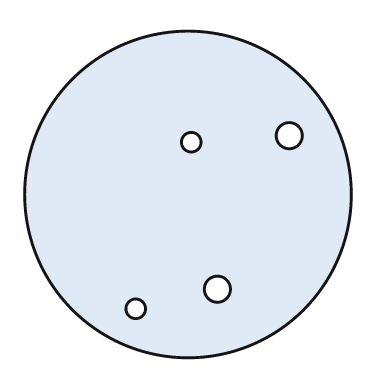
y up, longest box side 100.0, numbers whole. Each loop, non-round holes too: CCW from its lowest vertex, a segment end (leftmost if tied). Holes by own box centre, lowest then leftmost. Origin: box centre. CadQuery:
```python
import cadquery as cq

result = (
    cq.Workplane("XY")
    .moveTo(0.0, 0.0)
    .circle(50.0)
    .moveTo(-16.0, -35.0)
    .circle(3.0)
    .moveTo(9.0, -29.0)
    .circle(4.0)
    .moveTo(1.0, 16.0)
    .circle(3.0)
    .moveTo(31.0, 18.0)
    .circle(4.0)
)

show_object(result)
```